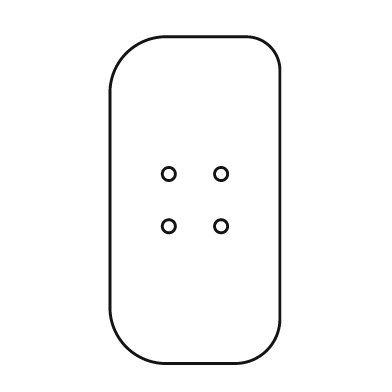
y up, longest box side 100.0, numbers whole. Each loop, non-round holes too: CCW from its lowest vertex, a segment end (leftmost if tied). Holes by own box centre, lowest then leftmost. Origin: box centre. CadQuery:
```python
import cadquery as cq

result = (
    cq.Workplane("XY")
    .moveTo(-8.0, -50.0)
    .lineTo(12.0, -50.0)
    .threePointArc((22.0, -46.0), (26.0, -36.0))
    .lineTo(26.0, 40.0)
    .threePointArc((23.0, 47.0), (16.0, 50.0))
    .lineTo(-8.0, 50.0)
    .threePointArc((-21.0, 45.0), (-26.0, 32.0))
    .lineTo(-26.0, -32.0)
    .threePointArc((-21.0, -45.0), (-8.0, -50.0))
    .close()
    .moveTo(-8.0, -8.0)
    .circle(2.0)
    .moveTo(8.0, -8.0)
    .circle(2.0)
    .moveTo(-8.0, 8.0)
    .circle(2.0)
    .moveTo(8.0, 8.0)
    .circle(2.0)
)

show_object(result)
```